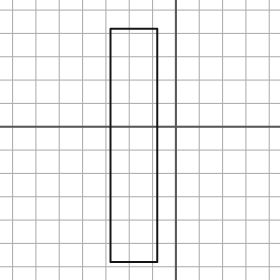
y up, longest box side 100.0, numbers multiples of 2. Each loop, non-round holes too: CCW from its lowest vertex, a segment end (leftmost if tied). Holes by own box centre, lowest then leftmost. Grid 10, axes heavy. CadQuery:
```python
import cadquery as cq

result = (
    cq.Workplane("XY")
    .moveTo(-28.0, -58.0)
    .lineTo(-8.0, -58.0)
    .lineTo(-8.0, 42.0)
    .lineTo(-28.0, 42.0)
    .close()
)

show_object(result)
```